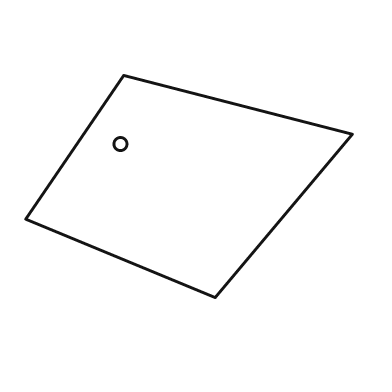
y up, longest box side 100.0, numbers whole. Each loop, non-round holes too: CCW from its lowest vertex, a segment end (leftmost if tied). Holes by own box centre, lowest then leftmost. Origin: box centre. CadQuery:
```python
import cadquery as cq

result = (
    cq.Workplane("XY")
    .moveTo(8.0, -34.0)
    .lineTo(50.0, 16.0)
    .lineTo(-20.0, 34.0)
    .lineTo(-50.0, -10.0)
    .close()
    .moveTo(-21.0, 13.0)
    .circle(2.0)
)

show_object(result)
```